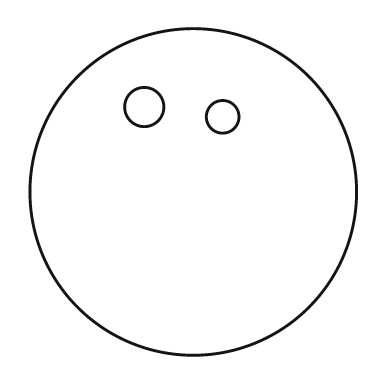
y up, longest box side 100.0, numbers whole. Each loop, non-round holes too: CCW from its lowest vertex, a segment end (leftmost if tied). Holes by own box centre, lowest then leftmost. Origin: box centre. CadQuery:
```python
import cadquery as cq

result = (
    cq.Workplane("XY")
    .moveTo(0.0, 0.0)
    .circle(50.0)
    .moveTo(9.0, 23.0)
    .circle(5.0)
    .moveTo(-15.0, 26.0)
    .circle(6.0)
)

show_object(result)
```